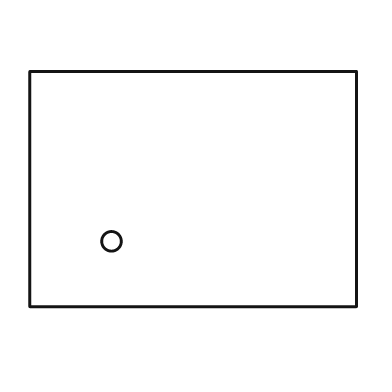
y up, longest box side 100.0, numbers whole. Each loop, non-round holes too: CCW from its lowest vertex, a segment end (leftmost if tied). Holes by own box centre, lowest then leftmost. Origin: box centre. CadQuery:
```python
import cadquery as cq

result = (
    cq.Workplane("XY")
    .moveTo(-50.0, -36.0)
    .lineTo(50.0, -36.0)
    .lineTo(50.0, 36.0)
    .lineTo(-50.0, 36.0)
    .close()
    .moveTo(-25.0, -16.0)
    .circle(3.0)
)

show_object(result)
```